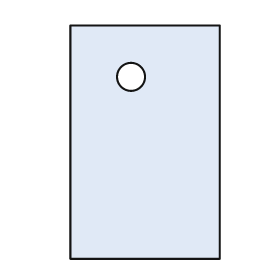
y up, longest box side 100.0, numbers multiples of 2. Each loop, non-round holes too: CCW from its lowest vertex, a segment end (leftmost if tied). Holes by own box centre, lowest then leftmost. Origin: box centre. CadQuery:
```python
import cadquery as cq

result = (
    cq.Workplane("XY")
    .moveTo(-32.0, -50.0)
    .lineTo(32.0, -50.0)
    .lineTo(32.0, 50.0)
    .lineTo(-32.0, 50.0)
    .close()
    .moveTo(-6.0, 28.0)
    .circle(6.0)
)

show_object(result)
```